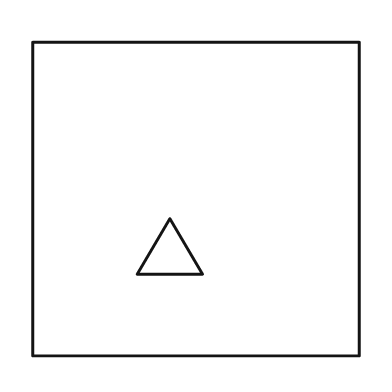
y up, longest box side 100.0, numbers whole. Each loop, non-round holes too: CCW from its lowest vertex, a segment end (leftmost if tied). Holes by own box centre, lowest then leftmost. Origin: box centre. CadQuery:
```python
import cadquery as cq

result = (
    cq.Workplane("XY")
    .moveTo(-50.0, -48.0)
    .lineTo(50.0, -48.0)
    .lineTo(50.0, 48.0)
    .lineTo(-50.0, 48.0)
    .close()
    .moveTo(-18.0, -23.0)
    .lineTo(2.0, -23.0)
    .lineTo(-8.0, -6.0)
    .close()
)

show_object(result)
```